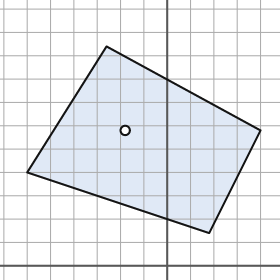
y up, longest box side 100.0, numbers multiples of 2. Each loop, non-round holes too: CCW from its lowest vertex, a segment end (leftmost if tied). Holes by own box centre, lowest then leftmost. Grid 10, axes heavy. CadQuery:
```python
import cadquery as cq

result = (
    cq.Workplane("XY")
    .moveTo(18.0, 14.0)
    .lineTo(40.0, 58.0)
    .lineTo(-26.0, 94.0)
    .lineTo(-60.0, 40.0)
    .close()
    .moveTo(-18.0, 58.0)
    .circle(2.0)
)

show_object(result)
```